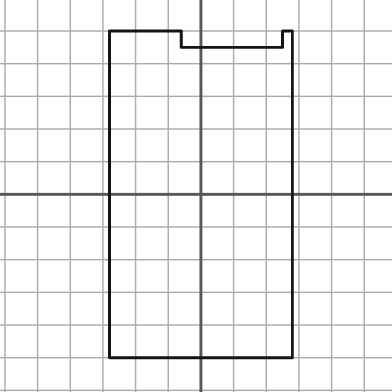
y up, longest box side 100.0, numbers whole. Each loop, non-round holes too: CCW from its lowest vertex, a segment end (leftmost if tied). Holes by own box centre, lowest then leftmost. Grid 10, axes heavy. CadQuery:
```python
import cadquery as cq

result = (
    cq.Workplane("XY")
    .moveTo(-28.0, -50.0)
    .lineTo(28.0, -50.0)
    .lineTo(28.0, 50.0)
    .lineTo(25.0, 50.0)
    .lineTo(25.0, 45.0)
    .lineTo(-6.0, 45.0)
    .lineTo(-6.0, 50.0)
    .lineTo(-28.0, 50.0)
    .close()
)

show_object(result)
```